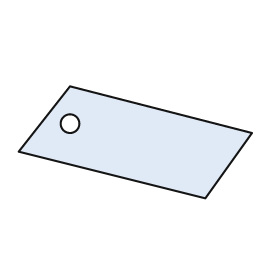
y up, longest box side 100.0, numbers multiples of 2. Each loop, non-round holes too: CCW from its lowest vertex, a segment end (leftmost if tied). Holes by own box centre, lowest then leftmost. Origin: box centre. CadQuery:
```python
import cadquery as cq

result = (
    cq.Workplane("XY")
    .moveTo(30.0, -24.0)
    .lineTo(50.0, 4.0)
    .lineTo(-28.0, 24.0)
    .lineTo(-50.0, -4.0)
    .close()
    .moveTo(-28.0, 8.0)
    .circle(4.0)
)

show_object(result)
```